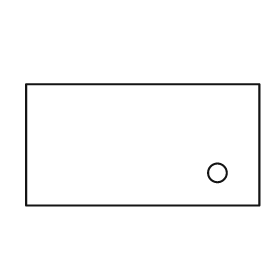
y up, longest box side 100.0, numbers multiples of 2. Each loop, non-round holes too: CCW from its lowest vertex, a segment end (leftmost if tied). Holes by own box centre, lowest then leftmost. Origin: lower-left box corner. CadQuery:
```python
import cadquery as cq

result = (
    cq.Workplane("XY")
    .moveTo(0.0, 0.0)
    .lineTo(100.0, 0.0)
    .lineTo(100.0, 52.0)
    .lineTo(0.0, 52.0)
    .close()
    .moveTo(82.0, 14.0)
    .circle(4.0)
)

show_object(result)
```